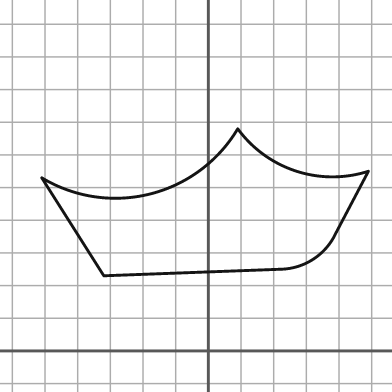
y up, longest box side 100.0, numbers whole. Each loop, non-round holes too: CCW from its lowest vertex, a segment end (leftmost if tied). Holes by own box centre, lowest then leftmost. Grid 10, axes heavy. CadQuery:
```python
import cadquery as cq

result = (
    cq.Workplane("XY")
    .moveTo(-32.0, 23.0)
    .lineTo(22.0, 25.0)
    .threePointArc((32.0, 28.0), (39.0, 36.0))
    .lineTo(49.0, 55.0)
    .threePointArc((27.0, 55.0), (9.0, 68.0))
    .threePointArc((-18.0, 48.0), (-51.0, 53.0))
    .close()
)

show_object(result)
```